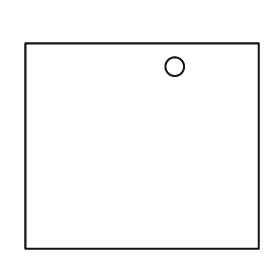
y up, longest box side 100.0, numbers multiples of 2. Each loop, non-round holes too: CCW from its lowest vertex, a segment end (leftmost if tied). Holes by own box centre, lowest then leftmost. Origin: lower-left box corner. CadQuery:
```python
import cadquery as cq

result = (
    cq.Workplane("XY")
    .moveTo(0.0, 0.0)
    .lineTo(100.0, 0.0)
    .lineTo(100.0, 88.0)
    .lineTo(0.0, 88.0)
    .close()
    .moveTo(64.0, 78.0)
    .circle(4.0)
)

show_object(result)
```